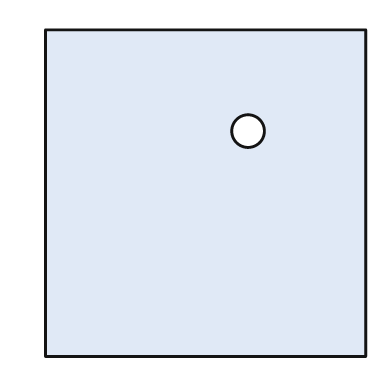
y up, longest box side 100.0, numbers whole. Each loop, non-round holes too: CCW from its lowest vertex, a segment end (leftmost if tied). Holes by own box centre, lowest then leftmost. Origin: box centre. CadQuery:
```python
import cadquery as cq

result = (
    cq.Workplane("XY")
    .moveTo(-49.0, -50.0)
    .lineTo(49.0, -50.0)
    .lineTo(49.0, 50.0)
    .lineTo(-49.0, 50.0)
    .close()
    .moveTo(13.0, 19.0)
    .circle(5.0)
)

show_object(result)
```